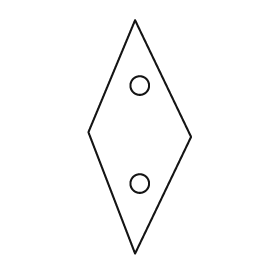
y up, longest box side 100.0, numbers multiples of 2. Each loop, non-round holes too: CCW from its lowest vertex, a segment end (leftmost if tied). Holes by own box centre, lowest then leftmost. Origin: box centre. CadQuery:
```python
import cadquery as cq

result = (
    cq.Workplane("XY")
    .moveTo(-2.0, -50.0)
    .lineTo(22.0, 0.0)
    .lineTo(-2.0, 50.0)
    .lineTo(-22.0, 2.0)
    .close()
    .moveTo(0.0, -20.0)
    .circle(4.0)
    .moveTo(0.0, 22.0)
    .circle(4.0)
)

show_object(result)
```